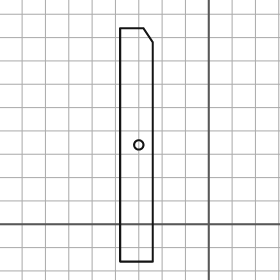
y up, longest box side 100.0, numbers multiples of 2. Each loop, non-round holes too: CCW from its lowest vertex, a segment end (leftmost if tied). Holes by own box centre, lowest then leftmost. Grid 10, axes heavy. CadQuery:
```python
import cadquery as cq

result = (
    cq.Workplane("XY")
    .moveTo(-38.0, -16.0)
    .lineTo(-24.0, -16.0)
    .lineTo(-24.0, 78.0)
    .lineTo(-28.0, 84.0)
    .lineTo(-38.0, 84.0)
    .close()
    .moveTo(-30.0, 34.0)
    .circle(2.0)
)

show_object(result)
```